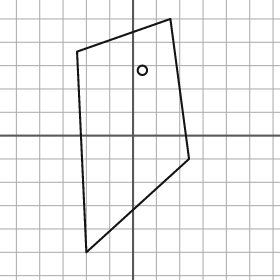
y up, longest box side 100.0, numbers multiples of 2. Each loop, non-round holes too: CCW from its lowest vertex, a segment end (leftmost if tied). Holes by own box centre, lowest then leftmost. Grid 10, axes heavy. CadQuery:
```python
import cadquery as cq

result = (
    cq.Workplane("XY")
    .moveTo(-20.0, -50.0)
    .lineTo(24.0, -10.0)
    .lineTo(16.0, 50.0)
    .lineTo(-24.0, 36.0)
    .close()
    .moveTo(4.0, 28.0)
    .circle(2.0)
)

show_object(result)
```